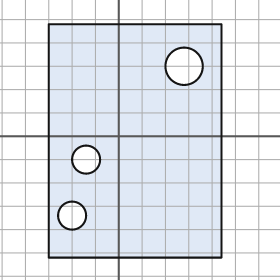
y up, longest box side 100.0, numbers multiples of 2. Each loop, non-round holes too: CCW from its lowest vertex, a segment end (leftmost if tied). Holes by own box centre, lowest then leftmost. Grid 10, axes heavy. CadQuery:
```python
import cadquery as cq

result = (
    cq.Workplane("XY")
    .moveTo(-30.0, -52.0)
    .lineTo(44.0, -52.0)
    .lineTo(44.0, 48.0)
    .lineTo(-30.0, 48.0)
    .close()
    .moveTo(-20.0, -34.0)
    .circle(6.0)
    .moveTo(-14.0, -10.0)
    .circle(6.0)
    .moveTo(28.0, 30.0)
    .circle(8.0)
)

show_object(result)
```